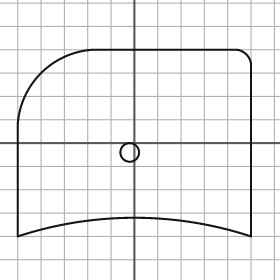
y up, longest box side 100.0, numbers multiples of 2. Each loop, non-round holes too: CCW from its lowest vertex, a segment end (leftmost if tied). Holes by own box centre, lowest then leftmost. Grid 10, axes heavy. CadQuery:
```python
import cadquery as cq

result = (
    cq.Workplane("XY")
    .moveTo(-50.0, -40.0)
    .threePointArc((0.0, -32.0), (50.0, -40.0))
    .lineTo(50.0, 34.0)
    .threePointArc((48.0, 38.0), (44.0, 40.0))
    .lineTo(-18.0, 40.0)
    .threePointArc((-40.0, 30.0), (-50.0, 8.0))
    .close()
    .moveTo(-2.0, -4.0)
    .circle(4.0)
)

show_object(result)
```